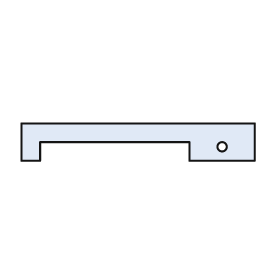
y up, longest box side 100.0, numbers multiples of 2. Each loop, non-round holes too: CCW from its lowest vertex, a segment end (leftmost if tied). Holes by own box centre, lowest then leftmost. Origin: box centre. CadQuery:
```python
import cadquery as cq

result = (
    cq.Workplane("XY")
    .moveTo(-50.0, -8.0)
    .lineTo(-42.0, -8.0)
    .lineTo(-42.0, 0.0)
    .lineTo(22.0, 0.0)
    .lineTo(22.0, -8.0)
    .lineTo(50.0, -8.0)
    .lineTo(50.0, 8.0)
    .lineTo(-50.0, 8.0)
    .close()
    .moveTo(36.0, -2.0)
    .circle(2.0)
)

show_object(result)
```